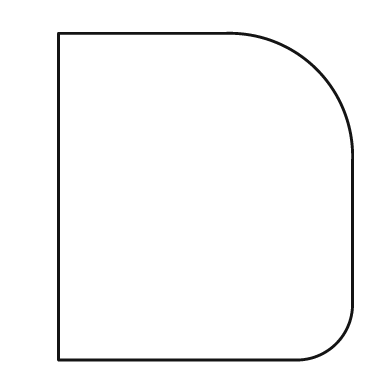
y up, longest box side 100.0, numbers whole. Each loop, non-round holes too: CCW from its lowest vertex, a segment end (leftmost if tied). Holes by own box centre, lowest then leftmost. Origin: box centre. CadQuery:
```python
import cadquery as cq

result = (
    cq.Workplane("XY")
    .moveTo(-45.0, -50.0)
    .lineTo(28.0, -50.0)
    .threePointArc((40.0, -45.0), (45.0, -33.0))
    .lineTo(45.0, 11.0)
    .threePointArc((34.0, 39.0), (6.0, 50.0))
    .lineTo(-45.0, 50.0)
    .close()
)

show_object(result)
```